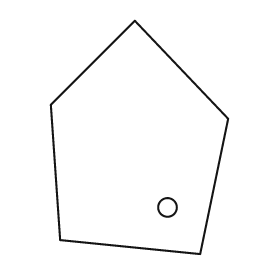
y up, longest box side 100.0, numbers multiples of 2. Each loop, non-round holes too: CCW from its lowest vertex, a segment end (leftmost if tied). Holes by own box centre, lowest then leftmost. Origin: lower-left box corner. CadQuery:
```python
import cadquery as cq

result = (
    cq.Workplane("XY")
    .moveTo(64.0, 0.0)
    .lineTo(76.0, 58.0)
    .lineTo(36.0, 100.0)
    .lineTo(0.0, 64.0)
    .lineTo(4.0, 6.0)
    .close()
    .moveTo(50.0, 20.0)
    .circle(4.0)
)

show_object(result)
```